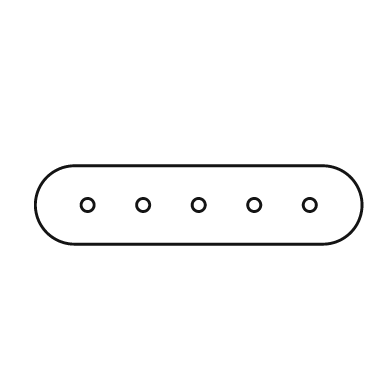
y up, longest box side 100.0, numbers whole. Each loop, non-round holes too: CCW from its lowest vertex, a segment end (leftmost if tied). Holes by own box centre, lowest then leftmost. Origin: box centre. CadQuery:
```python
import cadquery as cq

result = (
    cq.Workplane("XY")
    .moveTo(-38.0, -12.0)
    .lineTo(38.0, -12.0)
    .threePointArc((50.0, 0.0), (38.0, 12.0))
    .lineTo(-38.0, 12.0)
    .threePointArc((-50.0, 0.0), (-38.0, -12.0))
    .close()
    .moveTo(-34.0, 0.0)
    .circle(2.0)
    .moveTo(-17.0, 0.0)
    .circle(2.0)
    .moveTo(0.0, 0.0)
    .circle(2.0)
    .moveTo(17.0, 0.0)
    .circle(2.0)
    .moveTo(34.0, 0.0)
    .circle(2.0)
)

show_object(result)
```